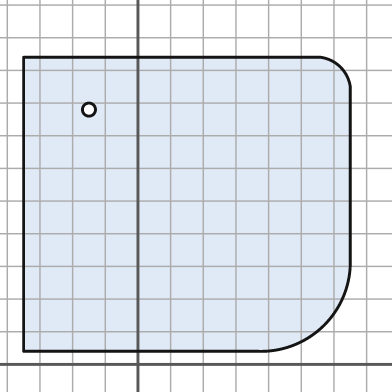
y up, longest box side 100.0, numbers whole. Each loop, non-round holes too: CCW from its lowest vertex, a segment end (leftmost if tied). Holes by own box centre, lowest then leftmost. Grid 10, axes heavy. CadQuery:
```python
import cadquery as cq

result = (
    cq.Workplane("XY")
    .moveTo(-35.0, 4.0)
    .lineTo(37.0, 4.0)
    .threePointArc((57.0, 12.0), (65.0, 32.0))
    .lineTo(65.0, 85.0)
    .threePointArc((62.0, 91.0), (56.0, 94.0))
    .lineTo(-35.0, 94.0)
    .close()
    .moveTo(-15.0, 78.0)
    .circle(2.0)
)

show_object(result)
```